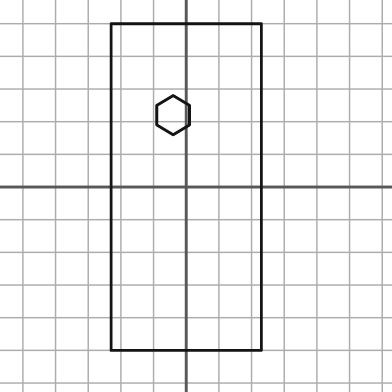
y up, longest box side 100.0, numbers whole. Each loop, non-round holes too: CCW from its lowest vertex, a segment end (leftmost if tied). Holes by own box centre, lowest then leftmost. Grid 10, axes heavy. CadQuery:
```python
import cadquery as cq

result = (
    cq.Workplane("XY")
    .moveTo(-23.0, -50.0)
    .lineTo(23.0, -50.0)
    .lineTo(23.0, 50.0)
    .lineTo(-23.0, 50.0)
    .close()
    .moveTo(-4.0, 16.0)
    .lineTo(1.0, 19.0)
    .lineTo(1.0, 25.0)
    .lineTo(-4.0, 28.0)
    .lineTo(-9.0, 25.0)
    .lineTo(-9.0, 19.0)
    .close()
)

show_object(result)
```